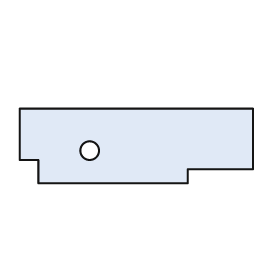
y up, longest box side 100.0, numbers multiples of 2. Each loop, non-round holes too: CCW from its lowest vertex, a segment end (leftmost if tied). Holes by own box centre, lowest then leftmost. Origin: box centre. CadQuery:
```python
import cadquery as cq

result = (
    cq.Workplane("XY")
    .moveTo(-42.0, -16.0)
    .lineTo(22.0, -16.0)
    .lineTo(22.0, -10.0)
    .lineTo(50.0, -10.0)
    .lineTo(50.0, 16.0)
    .lineTo(-50.0, 16.0)
    .lineTo(-50.0, -6.0)
    .lineTo(-42.0, -6.0)
    .close()
    .moveTo(-20.0, -2.0)
    .circle(4.0)
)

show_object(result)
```